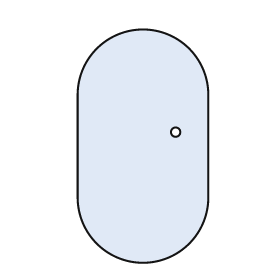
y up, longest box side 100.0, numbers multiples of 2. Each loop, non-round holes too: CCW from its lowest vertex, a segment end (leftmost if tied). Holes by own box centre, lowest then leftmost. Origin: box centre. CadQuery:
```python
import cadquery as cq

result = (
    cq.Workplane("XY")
    .moveTo(-28.0, -22.0)
    .threePointArc((0.0, -50.0), (28.0, -22.0))
    .lineTo(28.0, 22.0)
    .threePointArc((0.0, 50.0), (-28.0, 22.0))
    .close()
    .moveTo(14.0, 6.0)
    .circle(2.0)
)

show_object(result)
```